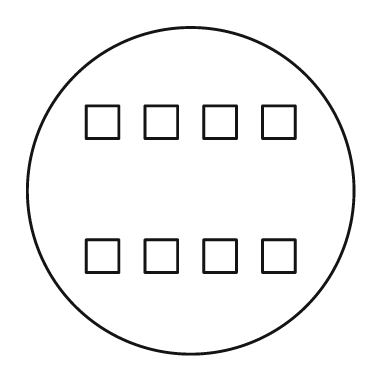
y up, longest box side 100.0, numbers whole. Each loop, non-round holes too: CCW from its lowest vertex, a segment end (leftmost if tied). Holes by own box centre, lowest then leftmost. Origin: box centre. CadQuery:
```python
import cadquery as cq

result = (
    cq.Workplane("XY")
    .moveTo(0.0, 0.0)
    .circle(50.0)
    .moveTo(-32.0, -25.0)
    .lineTo(-22.0, -25.0)
    .lineTo(-22.0, -15.0)
    .lineTo(-32.0, -15.0)
    .close()
    .moveTo(-14.0, -25.0)
    .lineTo(-4.0, -25.0)
    .lineTo(-4.0, -15.0)
    .lineTo(-14.0, -15.0)
    .close()
    .moveTo(4.0, -25.0)
    .lineTo(14.0, -25.0)
    .lineTo(14.0, -15.0)
    .lineTo(4.0, -15.0)
    .close()
    .moveTo(22.0, -25.0)
    .lineTo(32.0, -25.0)
    .lineTo(32.0, -15.0)
    .lineTo(22.0, -15.0)
    .close()
    .moveTo(-32.0, 16.0)
    .lineTo(-22.0, 16.0)
    .lineTo(-22.0, 26.0)
    .lineTo(-32.0, 26.0)
    .close()
    .moveTo(-14.0, 16.0)
    .lineTo(-4.0, 16.0)
    .lineTo(-4.0, 26.0)
    .lineTo(-14.0, 26.0)
    .close()
    .moveTo(4.0, 16.0)
    .lineTo(14.0, 16.0)
    .lineTo(14.0, 26.0)
    .lineTo(4.0, 26.0)
    .close()
    .moveTo(22.0, 16.0)
    .lineTo(32.0, 16.0)
    .lineTo(32.0, 26.0)
    .lineTo(22.0, 26.0)
    .close()
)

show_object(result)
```